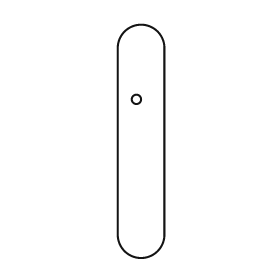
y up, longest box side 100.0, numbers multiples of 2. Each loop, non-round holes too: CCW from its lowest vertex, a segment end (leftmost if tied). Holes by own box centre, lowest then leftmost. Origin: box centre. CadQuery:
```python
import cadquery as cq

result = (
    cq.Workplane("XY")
    .moveTo(-10.0, -40.0)
    .threePointArc((0.0, -50.0), (10.0, -40.0))
    .lineTo(10.0, 40.0)
    .threePointArc((0.0, 50.0), (-10.0, 40.0))
    .close()
    .moveTo(-2.0, 18.0)
    .circle(2.0)
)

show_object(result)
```